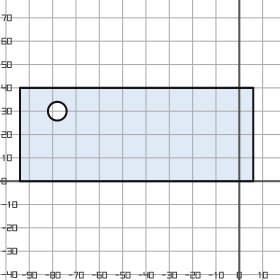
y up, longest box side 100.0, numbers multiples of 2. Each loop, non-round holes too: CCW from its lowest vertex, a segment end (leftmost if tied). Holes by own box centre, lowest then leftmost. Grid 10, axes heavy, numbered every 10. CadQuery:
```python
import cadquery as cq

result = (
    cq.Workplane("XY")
    .moveTo(-94.0, 0.0)
    .lineTo(6.0, 0.0)
    .lineTo(6.0, 40.0)
    .lineTo(-94.0, 40.0)
    .close()
    .moveTo(-78.0, 30.0)
    .circle(4.0)
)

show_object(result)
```